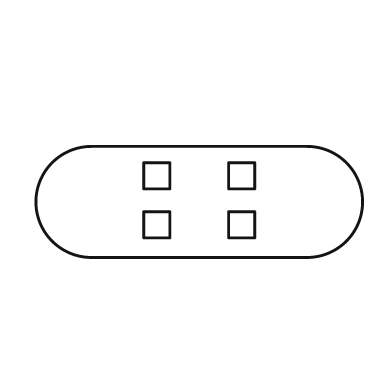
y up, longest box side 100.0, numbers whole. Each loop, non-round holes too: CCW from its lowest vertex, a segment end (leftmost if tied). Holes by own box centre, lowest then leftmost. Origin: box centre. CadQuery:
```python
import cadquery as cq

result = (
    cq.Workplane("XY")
    .moveTo(-33.0, -17.0)
    .lineTo(33.0, -17.0)
    .threePointArc((50.0, 0.0), (33.0, 17.0))
    .lineTo(-33.0, 17.0)
    .threePointArc((-50.0, 0.0), (-33.0, -17.0))
    .close()
    .moveTo(-17.0, -11.0)
    .lineTo(-9.0, -11.0)
    .lineTo(-9.0, -3.0)
    .lineTo(-17.0, -3.0)
    .close()
    .moveTo(9.0, -11.0)
    .lineTo(17.0, -11.0)
    .lineTo(17.0, -3.0)
    .lineTo(9.0, -3.0)
    .close()
    .moveTo(-17.0, 4.0)
    .lineTo(-9.0, 4.0)
    .lineTo(-9.0, 12.0)
    .lineTo(-17.0, 12.0)
    .close()
    .moveTo(9.0, 4.0)
    .lineTo(17.0, 4.0)
    .lineTo(17.0, 12.0)
    .lineTo(9.0, 12.0)
    .close()
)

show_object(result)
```